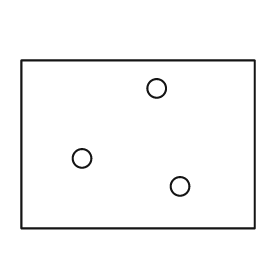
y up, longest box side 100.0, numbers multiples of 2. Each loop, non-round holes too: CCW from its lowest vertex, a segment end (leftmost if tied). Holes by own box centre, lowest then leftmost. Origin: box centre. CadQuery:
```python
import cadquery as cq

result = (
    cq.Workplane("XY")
    .moveTo(-50.0, -36.0)
    .lineTo(50.0, -36.0)
    .lineTo(50.0, 36.0)
    .lineTo(-50.0, 36.0)
    .close()
    .moveTo(18.0, -18.0)
    .circle(4.0)
    .moveTo(-24.0, -6.0)
    .circle(4.0)
    .moveTo(8.0, 24.0)
    .circle(4.0)
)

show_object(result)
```